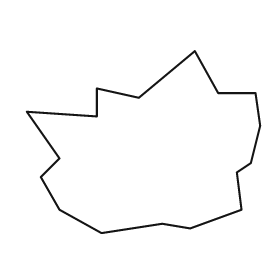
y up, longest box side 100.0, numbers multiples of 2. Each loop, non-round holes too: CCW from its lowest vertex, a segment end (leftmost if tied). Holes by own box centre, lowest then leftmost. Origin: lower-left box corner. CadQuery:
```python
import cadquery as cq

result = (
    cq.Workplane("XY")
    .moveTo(32.0, 0.0)
    .lineTo(58.0, 4.0)
    .lineTo(70.0, 2.0)
    .lineTo(92.0, 10.0)
    .lineTo(90.0, 26.0)
    .lineTo(96.0, 30.0)
    .lineTo(100.0, 46.0)
    .lineTo(98.0, 60.0)
    .lineTo(82.0, 60.0)
    .lineTo(72.0, 78.0)
    .lineTo(48.0, 58.0)
    .lineTo(30.0, 62.0)
    .lineTo(30.0, 50.0)
    .lineTo(0.0, 52.0)
    .lineTo(14.0, 32.0)
    .lineTo(6.0, 24.0)
    .lineTo(14.0, 10.0)
    .close()
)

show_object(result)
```